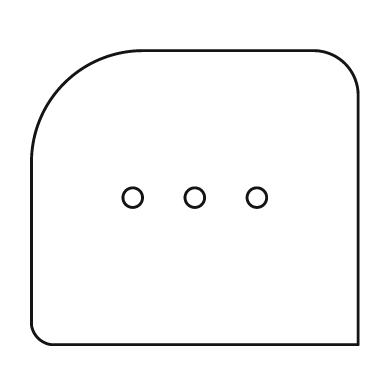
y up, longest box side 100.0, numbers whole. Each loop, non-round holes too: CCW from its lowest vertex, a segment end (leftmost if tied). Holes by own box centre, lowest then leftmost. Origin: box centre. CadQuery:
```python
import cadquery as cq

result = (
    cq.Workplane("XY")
    .moveTo(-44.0, -45.0)
    .lineTo(50.0, -45.0)
    .lineTo(50.0, 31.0)
    .threePointArc((46.0, 41.0), (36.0, 45.0))
    .lineTo(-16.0, 45.0)
    .threePointArc((-40.0, 35.0), (-50.0, 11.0))
    .lineTo(-50.0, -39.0)
    .threePointArc((-48.0, -43.0), (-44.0, -45.0))
    .close()
    .moveTo(-19.0, 0.0)
    .circle(3.0)
    .moveTo(0.0, 0.0)
    .circle(3.0)
    .moveTo(19.0, 0.0)
    .circle(3.0)
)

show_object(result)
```